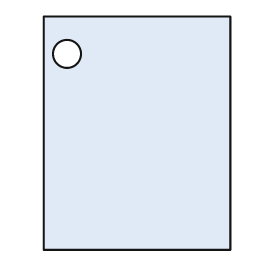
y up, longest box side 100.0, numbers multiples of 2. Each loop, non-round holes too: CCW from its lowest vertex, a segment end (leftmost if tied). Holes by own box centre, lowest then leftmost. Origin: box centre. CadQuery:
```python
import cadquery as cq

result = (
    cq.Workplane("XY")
    .moveTo(-40.0, -50.0)
    .lineTo(40.0, -50.0)
    .lineTo(40.0, 50.0)
    .lineTo(-40.0, 50.0)
    .close()
    .moveTo(-30.0, 34.0)
    .circle(6.0)
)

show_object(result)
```